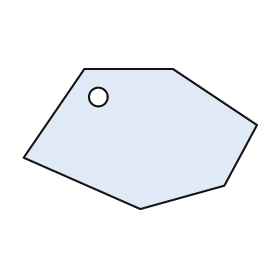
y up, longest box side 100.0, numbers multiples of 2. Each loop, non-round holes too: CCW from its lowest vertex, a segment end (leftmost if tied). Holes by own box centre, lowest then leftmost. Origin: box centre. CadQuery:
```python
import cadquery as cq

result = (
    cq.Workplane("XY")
    .moveTo(0.0, -30.0)
    .lineTo(36.0, -20.0)
    .lineTo(50.0, 6.0)
    .lineTo(14.0, 30.0)
    .lineTo(-24.0, 30.0)
    .lineTo(-50.0, -8.0)
    .close()
    .moveTo(-18.0, 18.0)
    .circle(4.0)
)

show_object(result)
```